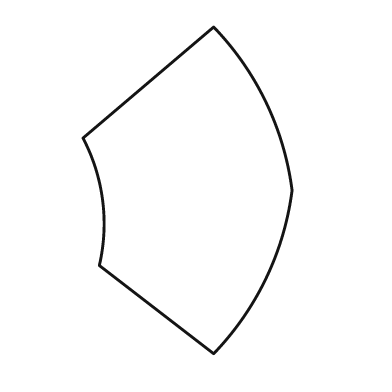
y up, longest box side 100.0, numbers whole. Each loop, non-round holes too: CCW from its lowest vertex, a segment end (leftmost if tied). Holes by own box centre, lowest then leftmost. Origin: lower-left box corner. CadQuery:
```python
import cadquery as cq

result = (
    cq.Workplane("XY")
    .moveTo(40.0, 0.0)
    .threePointArc((56.0, 23.0), (64.0, 50.0))
    .threePointArc((56.0, 77.0), (40.0, 100.0))
    .lineTo(0.0, 66.0)
    .threePointArc((6.0, 47.0), (5.0, 27.0))
    .close()
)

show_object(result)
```